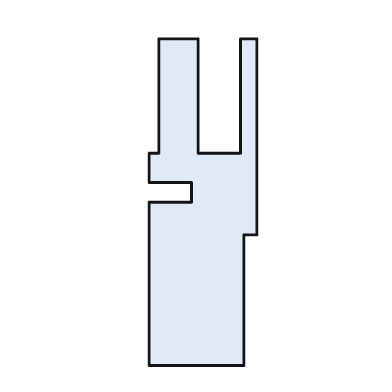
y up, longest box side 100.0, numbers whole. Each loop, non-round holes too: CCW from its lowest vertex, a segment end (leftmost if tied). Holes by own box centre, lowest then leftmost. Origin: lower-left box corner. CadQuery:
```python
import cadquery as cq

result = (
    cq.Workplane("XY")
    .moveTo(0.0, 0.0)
    .lineTo(29.0, 0.0)
    .lineTo(29.0, 40.0)
    .lineTo(33.0, 40.0)
    .lineTo(33.0, 100.0)
    .lineTo(28.0, 100.0)
    .lineTo(28.0, 65.0)
    .lineTo(15.0, 65.0)
    .lineTo(15.0, 100.0)
    .lineTo(3.0, 100.0)
    .lineTo(3.0, 65.0)
    .lineTo(0.0, 65.0)
    .lineTo(0.0, 56.0)
    .lineTo(13.0, 56.0)
    .lineTo(13.0, 50.0)
    .lineTo(0.0, 50.0)
    .close()
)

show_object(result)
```